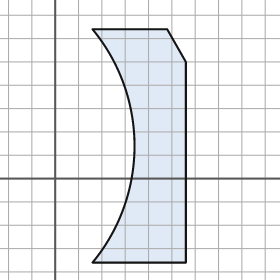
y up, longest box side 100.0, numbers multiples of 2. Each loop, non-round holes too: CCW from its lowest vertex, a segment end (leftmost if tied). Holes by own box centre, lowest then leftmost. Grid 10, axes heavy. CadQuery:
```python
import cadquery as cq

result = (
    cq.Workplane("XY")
    .moveTo(16.0, -36.0)
    .lineTo(56.0, -36.0)
    .lineTo(56.0, 50.0)
    .lineTo(48.0, 64.0)
    .lineTo(16.0, 64.0)
    .threePointArc((34.0, 14.0), (16.0, -36.0))
    .close()
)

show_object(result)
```